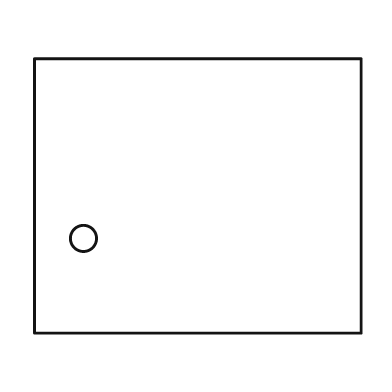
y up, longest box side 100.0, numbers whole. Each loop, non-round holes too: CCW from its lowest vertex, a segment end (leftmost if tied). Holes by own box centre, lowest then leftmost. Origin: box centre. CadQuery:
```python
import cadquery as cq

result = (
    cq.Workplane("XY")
    .moveTo(-50.0, -42.0)
    .lineTo(50.0, -42.0)
    .lineTo(50.0, 42.0)
    .lineTo(-50.0, 42.0)
    .close()
    .moveTo(-35.0, -13.0)
    .circle(4.0)
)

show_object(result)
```